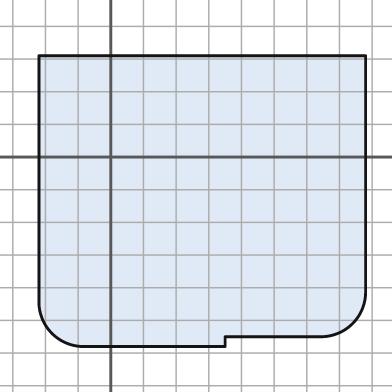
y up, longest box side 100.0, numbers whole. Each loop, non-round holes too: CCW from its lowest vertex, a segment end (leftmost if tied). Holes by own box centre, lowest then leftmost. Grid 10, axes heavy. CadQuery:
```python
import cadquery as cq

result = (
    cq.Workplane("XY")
    .moveTo(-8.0, -58.0)
    .lineTo(35.0, -58.0)
    .lineTo(35.0, -55.0)
    .lineTo(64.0, -55.0)
    .threePointArc((74.0, -51.0), (78.0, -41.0))
    .lineTo(78.0, 31.0)
    .lineTo(-22.0, 31.0)
    .lineTo(-22.0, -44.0)
    .threePointArc((-18.0, -54.0), (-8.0, -58.0))
    .close()
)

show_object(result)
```